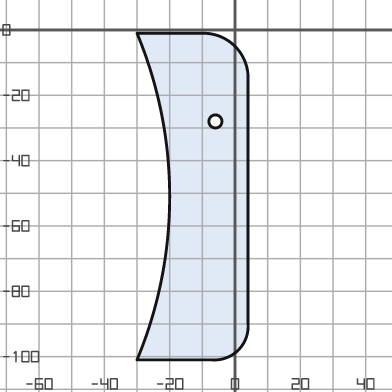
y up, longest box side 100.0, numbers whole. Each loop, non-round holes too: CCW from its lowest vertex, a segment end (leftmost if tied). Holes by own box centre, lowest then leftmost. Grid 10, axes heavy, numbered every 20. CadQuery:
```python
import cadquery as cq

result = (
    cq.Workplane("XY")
    .moveTo(-30.0, -101.0)
    .lineTo(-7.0, -101.0)
    .threePointArc((1.0, -98.0), (4.0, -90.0))
    .lineTo(4.0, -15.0)
    .threePointArc((0.0, -5.0), (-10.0, -1.0))
    .lineTo(-30.0, -1.0)
    .threePointArc((-20.0, -51.0), (-30.0, -101.0))
    .close()
    .moveTo(-6.0, -28.0)
    .circle(2.0)
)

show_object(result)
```